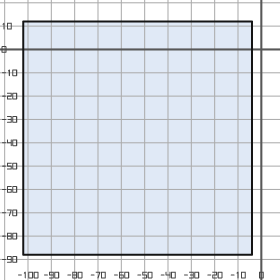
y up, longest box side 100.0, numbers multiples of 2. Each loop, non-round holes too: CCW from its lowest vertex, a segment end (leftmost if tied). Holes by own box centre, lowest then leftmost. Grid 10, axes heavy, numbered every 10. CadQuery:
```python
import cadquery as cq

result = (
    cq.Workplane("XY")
    .moveTo(-102.0, -88.0)
    .lineTo(-4.0, -88.0)
    .lineTo(-4.0, 12.0)
    .lineTo(-102.0, 12.0)
    .close()
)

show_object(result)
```